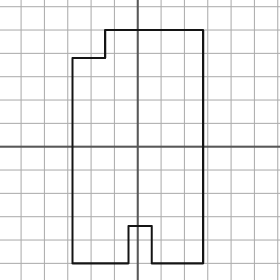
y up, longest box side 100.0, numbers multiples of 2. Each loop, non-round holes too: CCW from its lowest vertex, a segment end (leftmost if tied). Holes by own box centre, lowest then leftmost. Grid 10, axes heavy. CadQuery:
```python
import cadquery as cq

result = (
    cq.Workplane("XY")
    .moveTo(-28.0, -50.0)
    .lineTo(-4.0, -50.0)
    .lineTo(-4.0, -34.0)
    .lineTo(6.0, -34.0)
    .lineTo(6.0, -50.0)
    .lineTo(28.0, -50.0)
    .lineTo(28.0, 50.0)
    .lineTo(-14.0, 50.0)
    .lineTo(-14.0, 38.0)
    .lineTo(-28.0, 38.0)
    .close()
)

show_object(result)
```